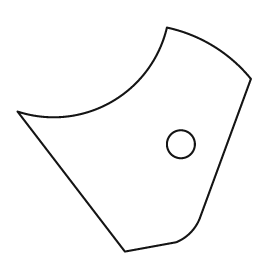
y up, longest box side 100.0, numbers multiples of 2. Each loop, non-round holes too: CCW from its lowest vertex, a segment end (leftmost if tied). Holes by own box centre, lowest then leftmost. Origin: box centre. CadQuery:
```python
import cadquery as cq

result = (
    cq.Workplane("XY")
    .moveTo(-4.0, -48.0)
    .lineTo(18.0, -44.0)
    .threePointArc((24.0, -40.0), (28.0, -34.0))
    .lineTo(50.0, 26.0)
    .threePointArc((34.0, 40.0), (14.0, 48.0))
    .threePointArc((-10.0, 16.0), (-50.0, 12.0))
    .close()
    .moveTo(20.0, -2.0)
    .circle(6.0)
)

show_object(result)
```